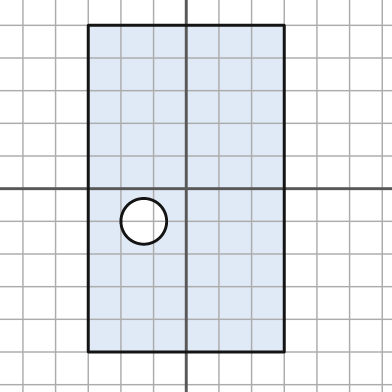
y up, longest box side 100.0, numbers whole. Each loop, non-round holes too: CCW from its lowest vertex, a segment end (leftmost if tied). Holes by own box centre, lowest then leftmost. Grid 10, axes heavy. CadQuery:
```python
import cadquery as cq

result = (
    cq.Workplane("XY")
    .moveTo(-30.0, -50.0)
    .lineTo(30.0, -50.0)
    .lineTo(30.0, 50.0)
    .lineTo(-30.0, 50.0)
    .close()
    .moveTo(-13.0, -10.0)
    .circle(7.0)
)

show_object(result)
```